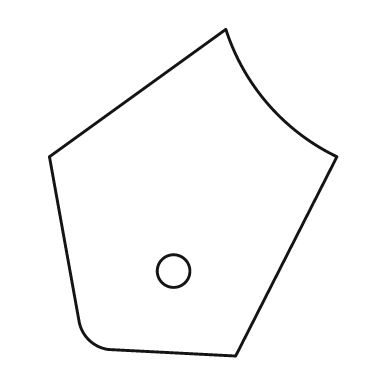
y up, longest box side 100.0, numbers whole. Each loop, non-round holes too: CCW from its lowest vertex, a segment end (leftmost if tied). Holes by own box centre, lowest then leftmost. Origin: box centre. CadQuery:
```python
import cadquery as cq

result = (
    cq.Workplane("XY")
    .moveTo(13.0, -50.0)
    .lineTo(44.0, 11.0)
    .threePointArc((23.0, 27.0), (10.0, 50.0))
    .lineTo(-44.0, 11.0)
    .lineTo(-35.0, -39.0)
    .threePointArc((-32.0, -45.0), (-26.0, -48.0))
    .close()
    .moveTo(-6.0, -24.0)
    .circle(5.0)
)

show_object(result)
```